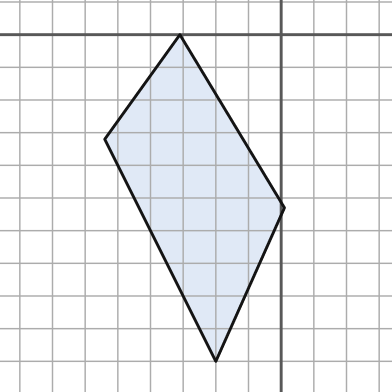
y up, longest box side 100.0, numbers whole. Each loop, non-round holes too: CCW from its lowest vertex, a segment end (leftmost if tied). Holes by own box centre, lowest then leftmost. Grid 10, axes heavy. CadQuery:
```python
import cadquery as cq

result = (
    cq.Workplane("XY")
    .moveTo(-20.0, -100.0)
    .lineTo(1.0, -53.0)
    .lineTo(-31.0, 0.0)
    .lineTo(-54.0, -32.0)
    .close()
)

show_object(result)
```